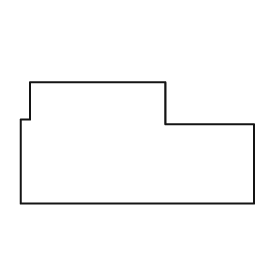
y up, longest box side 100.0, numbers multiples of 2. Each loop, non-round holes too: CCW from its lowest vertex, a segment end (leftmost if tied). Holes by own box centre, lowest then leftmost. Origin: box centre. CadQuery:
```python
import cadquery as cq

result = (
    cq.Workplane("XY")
    .moveTo(-50.0, -26.0)
    .lineTo(50.0, -26.0)
    .lineTo(50.0, 8.0)
    .lineTo(12.0, 8.0)
    .lineTo(12.0, 26.0)
    .lineTo(-46.0, 26.0)
    .lineTo(-46.0, 10.0)
    .lineTo(-50.0, 10.0)
    .close()
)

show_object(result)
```